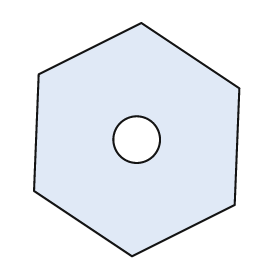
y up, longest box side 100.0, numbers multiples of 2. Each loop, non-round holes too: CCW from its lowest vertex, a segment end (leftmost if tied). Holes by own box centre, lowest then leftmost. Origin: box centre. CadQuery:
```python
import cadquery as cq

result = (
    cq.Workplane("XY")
    .moveTo(-2.0, -50.0)
    .lineTo(42.0, -28.0)
    .lineTo(44.0, 22.0)
    .lineTo(2.0, 50.0)
    .lineTo(-42.0, 28.0)
    .lineTo(-44.0, -22.0)
    .close()
    .moveTo(0.0, 0.0)
    .circle(10.0)
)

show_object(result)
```